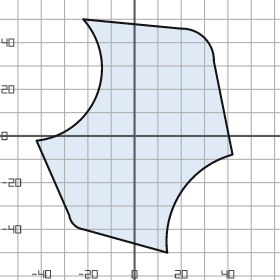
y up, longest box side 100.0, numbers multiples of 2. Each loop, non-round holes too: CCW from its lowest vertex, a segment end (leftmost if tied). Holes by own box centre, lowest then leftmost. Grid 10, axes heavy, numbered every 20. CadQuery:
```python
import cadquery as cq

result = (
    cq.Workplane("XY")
    .moveTo(14.0, -50.0)
    .threePointArc((20.0, -24.0), (42.0, -8.0))
    .lineTo(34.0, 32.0)
    .threePointArc((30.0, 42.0), (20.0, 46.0))
    .lineTo(-22.0, 50.0)
    .threePointArc((-16.0, 18.0), (-42.0, -2.0))
    .lineTo(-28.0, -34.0)
    .threePointArc((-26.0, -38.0), (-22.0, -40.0))
    .close()
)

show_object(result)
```